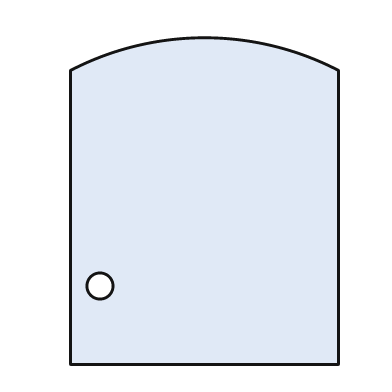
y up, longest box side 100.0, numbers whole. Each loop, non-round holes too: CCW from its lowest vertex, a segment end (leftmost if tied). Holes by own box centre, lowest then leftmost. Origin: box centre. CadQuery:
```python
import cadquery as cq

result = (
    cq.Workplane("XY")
    .moveTo(-41.0, -50.0)
    .lineTo(41.0, -50.0)
    .lineTo(41.0, 40.0)
    .threePointArc((0.0, 50.0), (-41.0, 40.0))
    .close()
    .moveTo(-32.0, -26.0)
    .circle(4.0)
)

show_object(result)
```